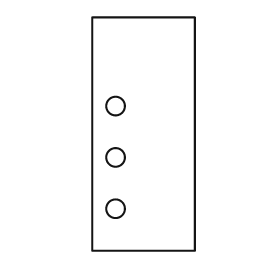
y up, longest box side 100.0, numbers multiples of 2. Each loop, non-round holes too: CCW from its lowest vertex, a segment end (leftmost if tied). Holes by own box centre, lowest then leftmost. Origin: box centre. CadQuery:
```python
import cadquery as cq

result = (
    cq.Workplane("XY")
    .moveTo(-22.0, -50.0)
    .lineTo(22.0, -50.0)
    .lineTo(22.0, 50.0)
    .lineTo(-22.0, 50.0)
    .close()
    .moveTo(-12.0, -32.0)
    .circle(4.0)
    .moveTo(-12.0, -10.0)
    .circle(4.0)
    .moveTo(-12.0, 12.0)
    .circle(4.0)
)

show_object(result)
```